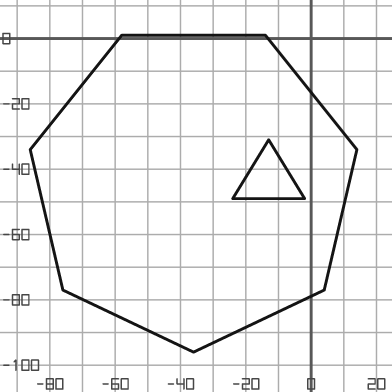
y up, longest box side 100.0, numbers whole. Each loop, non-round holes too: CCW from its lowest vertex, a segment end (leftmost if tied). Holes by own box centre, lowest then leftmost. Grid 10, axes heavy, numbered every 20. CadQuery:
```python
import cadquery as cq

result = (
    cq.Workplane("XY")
    .moveTo(-36.0, -96.0)
    .lineTo(4.0, -77.0)
    .lineTo(14.0, -34.0)
    .lineTo(-14.0, 1.0)
    .lineTo(-58.0, 1.0)
    .lineTo(-86.0, -34.0)
    .lineTo(-76.0, -77.0)
    .close()
    .moveTo(-24.0, -49.0)
    .lineTo(-2.0, -49.0)
    .lineTo(-13.0, -31.0)
    .close()
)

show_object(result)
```